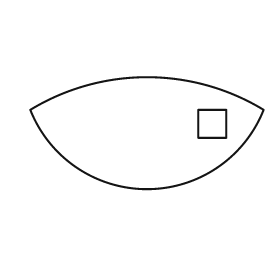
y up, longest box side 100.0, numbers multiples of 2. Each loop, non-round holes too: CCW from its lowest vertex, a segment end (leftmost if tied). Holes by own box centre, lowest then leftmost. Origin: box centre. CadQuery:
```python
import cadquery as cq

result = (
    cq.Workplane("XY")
    .moveTo(-50.0, 10.0)
    .threePointArc((0.0, -24.0), (50.0, 10.0))
    .threePointArc((0.0, 24.0), (-50.0, 10.0))
    .close()
    .moveTo(22.0, -2.0)
    .lineTo(34.0, -2.0)
    .lineTo(34.0, 10.0)
    .lineTo(22.0, 10.0)
    .close()
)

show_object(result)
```